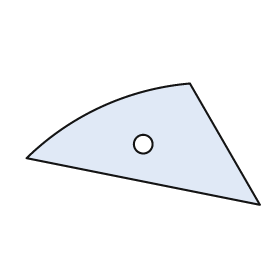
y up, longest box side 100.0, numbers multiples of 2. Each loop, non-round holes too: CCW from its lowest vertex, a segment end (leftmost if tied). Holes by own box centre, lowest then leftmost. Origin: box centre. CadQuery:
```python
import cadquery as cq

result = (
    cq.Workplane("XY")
    .moveTo(50.0, -26.0)
    .lineTo(20.0, 26.0)
    .threePointArc((-18.0, 16.0), (-50.0, -6.0))
    .close()
    .moveTo(0.0, 0.0)
    .circle(4.0)
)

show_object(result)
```